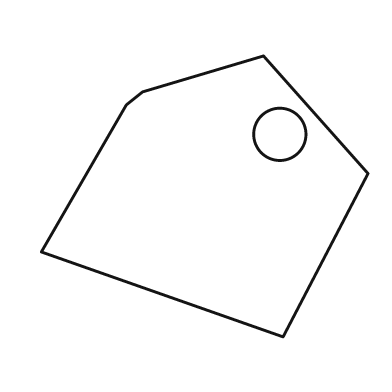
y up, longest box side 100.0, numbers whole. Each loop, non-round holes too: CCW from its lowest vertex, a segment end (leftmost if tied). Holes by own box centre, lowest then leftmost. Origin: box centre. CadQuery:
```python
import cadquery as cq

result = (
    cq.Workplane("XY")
    .moveTo(24.0, -43.0)
    .lineTo(50.0, 7.0)
    .lineTo(18.0, 43.0)
    .lineTo(-19.0, 32.0)
    .lineTo(-24.0, 28.0)
    .lineTo(-50.0, -17.0)
    .close()
    .moveTo(23.0, 19.0)
    .circle(8.0)
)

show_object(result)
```